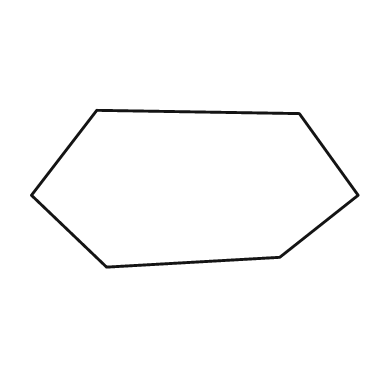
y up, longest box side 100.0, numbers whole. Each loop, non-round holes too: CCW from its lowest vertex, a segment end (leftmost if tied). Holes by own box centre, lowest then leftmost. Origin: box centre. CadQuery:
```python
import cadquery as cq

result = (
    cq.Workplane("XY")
    .moveTo(-27.0, -24.0)
    .lineTo(26.0, -21.0)
    .lineTo(50.0, -2.0)
    .lineTo(32.0, 23.0)
    .lineTo(-30.0, 24.0)
    .lineTo(-50.0, -2.0)
    .close()
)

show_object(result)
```